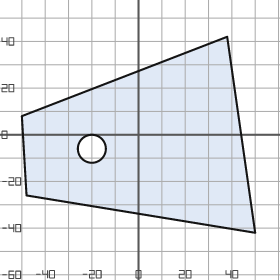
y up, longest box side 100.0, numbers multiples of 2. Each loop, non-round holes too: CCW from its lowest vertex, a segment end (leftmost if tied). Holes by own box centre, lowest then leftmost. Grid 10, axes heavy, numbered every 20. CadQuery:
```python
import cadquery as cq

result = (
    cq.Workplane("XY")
    .moveTo(50.0, -42.0)
    .lineTo(38.0, 42.0)
    .lineTo(-50.0, 8.0)
    .lineTo(-48.0, -26.0)
    .close()
    .moveTo(-20.0, -6.0)
    .circle(6.0)
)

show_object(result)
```